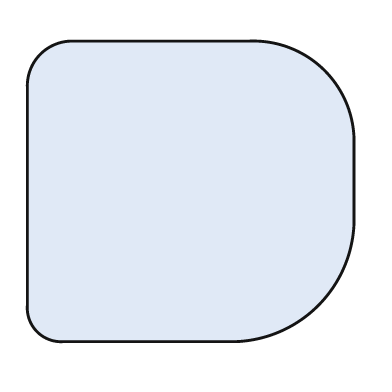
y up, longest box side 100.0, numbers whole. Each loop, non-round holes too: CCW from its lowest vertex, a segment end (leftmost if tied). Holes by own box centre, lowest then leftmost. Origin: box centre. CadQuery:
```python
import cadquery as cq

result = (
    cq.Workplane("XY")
    .moveTo(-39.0, -46.0)
    .lineTo(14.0, -46.0)
    .threePointArc((39.0, -35.0), (50.0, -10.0))
    .lineTo(50.0, 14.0)
    .threePointArc((41.0, 37.0), (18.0, 46.0))
    .lineTo(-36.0, 46.0)
    .threePointArc((-46.0, 42.0), (-50.0, 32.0))
    .lineTo(-50.0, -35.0)
    .threePointArc((-47.0, -43.0), (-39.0, -46.0))
    .close()
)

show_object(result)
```